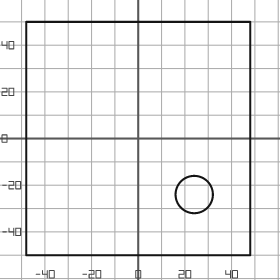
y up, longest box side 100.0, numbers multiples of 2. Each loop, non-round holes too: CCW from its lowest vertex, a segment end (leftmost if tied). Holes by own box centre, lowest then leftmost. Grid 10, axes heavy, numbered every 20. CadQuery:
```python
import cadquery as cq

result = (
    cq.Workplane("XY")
    .moveTo(-48.0, -50.0)
    .lineTo(48.0, -50.0)
    .lineTo(48.0, 50.0)
    .lineTo(-48.0, 50.0)
    .close()
    .moveTo(24.0, -24.0)
    .circle(8.0)
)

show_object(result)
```